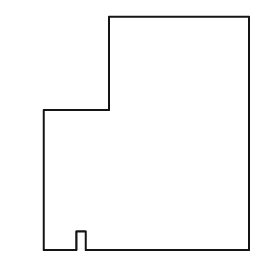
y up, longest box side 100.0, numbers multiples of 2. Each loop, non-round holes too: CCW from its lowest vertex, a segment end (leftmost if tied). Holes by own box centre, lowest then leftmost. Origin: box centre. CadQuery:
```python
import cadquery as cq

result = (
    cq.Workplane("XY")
    .moveTo(-44.0, -50.0)
    .lineTo(-30.0, -50.0)
    .lineTo(-30.0, -42.0)
    .lineTo(-26.0, -42.0)
    .lineTo(-26.0, -50.0)
    .lineTo(44.0, -50.0)
    .lineTo(44.0, 50.0)
    .lineTo(-16.0, 50.0)
    .lineTo(-16.0, 10.0)
    .lineTo(-44.0, 10.0)
    .close()
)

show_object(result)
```